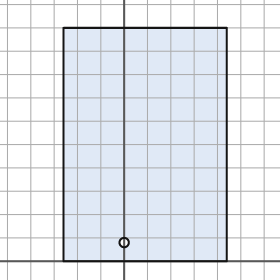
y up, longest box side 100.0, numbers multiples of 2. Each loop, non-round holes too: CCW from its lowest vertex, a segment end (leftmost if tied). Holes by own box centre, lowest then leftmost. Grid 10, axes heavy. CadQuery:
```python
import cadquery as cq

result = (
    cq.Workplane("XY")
    .moveTo(-26.0, 0.0)
    .lineTo(44.0, 0.0)
    .lineTo(44.0, 100.0)
    .lineTo(-26.0, 100.0)
    .close()
    .moveTo(0.0, 8.0)
    .circle(2.0)
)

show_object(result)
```